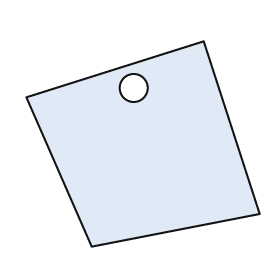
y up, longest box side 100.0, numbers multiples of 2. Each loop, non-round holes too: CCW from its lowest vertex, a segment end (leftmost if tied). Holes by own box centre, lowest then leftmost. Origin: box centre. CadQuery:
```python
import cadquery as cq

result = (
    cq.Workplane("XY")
    .moveTo(-22.0, -44.0)
    .lineTo(50.0, -30.0)
    .lineTo(26.0, 44.0)
    .lineTo(-50.0, 20.0)
    .close()
    .moveTo(-4.0, 24.0)
    .circle(6.0)
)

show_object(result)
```